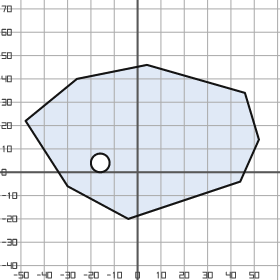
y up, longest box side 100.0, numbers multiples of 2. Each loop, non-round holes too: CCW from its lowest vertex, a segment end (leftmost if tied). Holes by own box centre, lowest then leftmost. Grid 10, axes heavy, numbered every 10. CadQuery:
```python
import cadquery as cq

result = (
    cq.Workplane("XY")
    .moveTo(-4.0, -20.0)
    .lineTo(44.0, -4.0)
    .lineTo(52.0, 14.0)
    .lineTo(46.0, 34.0)
    .lineTo(4.0, 46.0)
    .lineTo(-26.0, 40.0)
    .lineTo(-48.0, 22.0)
    .lineTo(-30.0, -6.0)
    .close()
    .moveTo(-16.0, 4.0)
    .circle(4.0)
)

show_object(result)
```